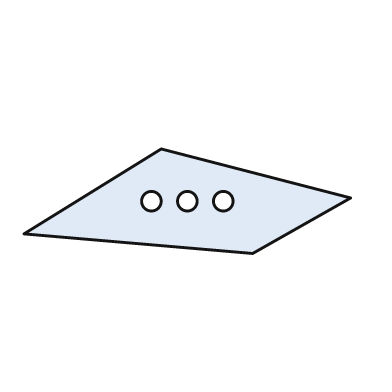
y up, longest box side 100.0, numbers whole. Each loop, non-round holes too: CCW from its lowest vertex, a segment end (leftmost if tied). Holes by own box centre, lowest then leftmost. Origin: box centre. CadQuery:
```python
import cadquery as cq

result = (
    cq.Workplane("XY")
    .moveTo(20.0, -16.0)
    .lineTo(50.0, 1.0)
    .lineTo(-8.0, 16.0)
    .lineTo(-50.0, -10.0)
    .close()
    .moveTo(-11.0, 0.0)
    .circle(3.0)
    .moveTo(0.0, 0.0)
    .circle(3.0)
    .moveTo(11.0, 0.0)
    .circle(3.0)
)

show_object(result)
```